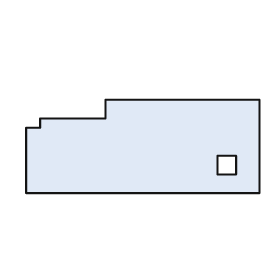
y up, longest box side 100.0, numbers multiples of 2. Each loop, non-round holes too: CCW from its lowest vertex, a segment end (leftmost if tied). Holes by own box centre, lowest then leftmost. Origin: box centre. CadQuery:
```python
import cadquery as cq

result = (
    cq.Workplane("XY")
    .moveTo(-50.0, -20.0)
    .lineTo(50.0, -20.0)
    .lineTo(50.0, 20.0)
    .lineTo(-16.0, 20.0)
    .lineTo(-16.0, 12.0)
    .lineTo(-44.0, 12.0)
    .lineTo(-44.0, 8.0)
    .lineTo(-50.0, 8.0)
    .close()
    .moveTo(32.0, -12.0)
    .lineTo(40.0, -12.0)
    .lineTo(40.0, -4.0)
    .lineTo(32.0, -4.0)
    .close()
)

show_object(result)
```